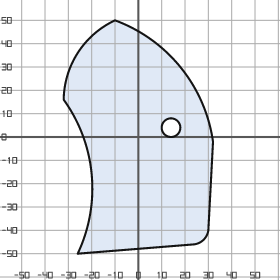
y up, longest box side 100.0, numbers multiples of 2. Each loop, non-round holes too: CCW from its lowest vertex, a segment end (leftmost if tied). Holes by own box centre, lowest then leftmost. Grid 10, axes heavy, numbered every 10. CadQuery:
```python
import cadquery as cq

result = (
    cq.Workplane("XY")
    .moveTo(-26.0, -50.0)
    .lineTo(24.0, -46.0)
    .threePointArc((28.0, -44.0), (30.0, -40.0))
    .lineTo(32.0, -2.0)
    .threePointArc((18.0, 30.0), (-10.0, 50.0))
    .threePointArc((-26.0, 36.0), (-32.0, 16.0))
    .threePointArc((-20.0, -16.0), (-26.0, -50.0))
    .close()
    .moveTo(14.0, 4.0)
    .circle(4.0)
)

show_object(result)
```